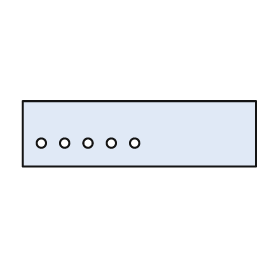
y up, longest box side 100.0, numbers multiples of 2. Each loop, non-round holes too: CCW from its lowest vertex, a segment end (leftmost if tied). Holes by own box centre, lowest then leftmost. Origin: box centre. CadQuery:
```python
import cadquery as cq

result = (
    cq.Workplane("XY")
    .moveTo(-50.0, -14.0)
    .lineTo(50.0, -14.0)
    .lineTo(50.0, 14.0)
    .lineTo(-50.0, 14.0)
    .close()
    .moveTo(-42.0, -4.0)
    .circle(2.0)
    .moveTo(-32.0, -4.0)
    .circle(2.0)
    .moveTo(-22.0, -4.0)
    .circle(2.0)
    .moveTo(-12.0, -4.0)
    .circle(2.0)
    .moveTo(-2.0, -4.0)
    .circle(2.0)
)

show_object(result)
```